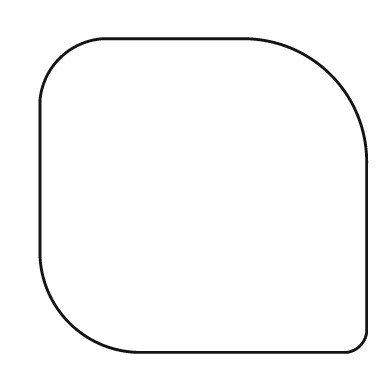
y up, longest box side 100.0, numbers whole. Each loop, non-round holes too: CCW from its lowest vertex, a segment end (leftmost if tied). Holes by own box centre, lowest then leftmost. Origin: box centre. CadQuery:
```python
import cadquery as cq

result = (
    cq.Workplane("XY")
    .moveTo(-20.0, -48.0)
    .lineTo(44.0, -48.0)
    .threePointArc((48.0, -46.0), (50.0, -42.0))
    .lineTo(50.0, 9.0)
    .threePointArc((39.0, 37.0), (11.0, 48.0))
    .lineTo(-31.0, 48.0)
    .threePointArc((-44.0, 42.0), (-50.0, 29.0))
    .lineTo(-50.0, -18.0)
    .threePointArc((-41.0, -39.0), (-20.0, -48.0))
    .close()
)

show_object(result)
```